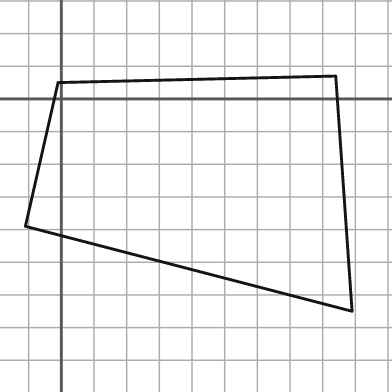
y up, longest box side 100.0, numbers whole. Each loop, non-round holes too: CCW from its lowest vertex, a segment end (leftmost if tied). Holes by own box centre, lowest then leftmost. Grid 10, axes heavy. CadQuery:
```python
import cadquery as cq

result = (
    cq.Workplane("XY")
    .moveTo(89.0, -65.0)
    .lineTo(84.0, 7.0)
    .lineTo(-1.0, 5.0)
    .lineTo(-11.0, -39.0)
    .close()
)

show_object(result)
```